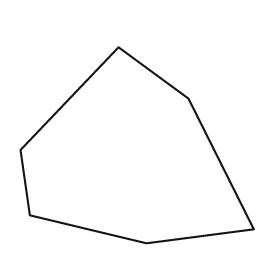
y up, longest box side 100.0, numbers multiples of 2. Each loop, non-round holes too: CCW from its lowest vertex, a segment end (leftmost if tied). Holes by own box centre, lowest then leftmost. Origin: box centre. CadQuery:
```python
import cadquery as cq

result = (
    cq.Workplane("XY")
    .moveTo(4.0, -42.0)
    .lineTo(50.0, -36.0)
    .lineTo(22.0, 20.0)
    .lineTo(-8.0, 42.0)
    .lineTo(-50.0, -2.0)
    .lineTo(-46.0, -30.0)
    .close()
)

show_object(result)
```